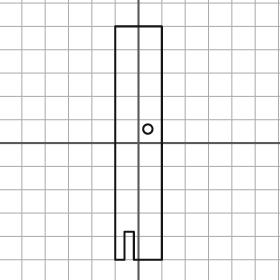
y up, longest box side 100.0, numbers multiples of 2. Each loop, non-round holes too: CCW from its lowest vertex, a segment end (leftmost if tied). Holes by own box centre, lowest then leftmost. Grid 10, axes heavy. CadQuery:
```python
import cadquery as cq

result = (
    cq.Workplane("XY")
    .moveTo(-10.0, -50.0)
    .lineTo(-6.0, -50.0)
    .lineTo(-6.0, -38.0)
    .lineTo(-2.0, -38.0)
    .lineTo(-2.0, -50.0)
    .lineTo(10.0, -50.0)
    .lineTo(10.0, 50.0)
    .lineTo(-10.0, 50.0)
    .close()
    .moveTo(4.0, 6.0)
    .circle(2.0)
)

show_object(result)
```